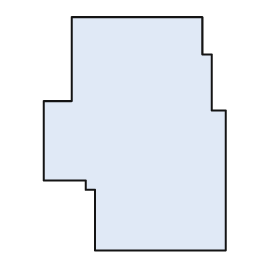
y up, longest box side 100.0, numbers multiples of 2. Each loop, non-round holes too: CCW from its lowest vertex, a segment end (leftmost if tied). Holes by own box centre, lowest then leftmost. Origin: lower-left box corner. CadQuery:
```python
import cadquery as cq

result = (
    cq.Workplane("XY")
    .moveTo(22.0, 0.0)
    .lineTo(78.0, 0.0)
    .lineTo(78.0, 60.0)
    .lineTo(72.0, 60.0)
    .lineTo(72.0, 84.0)
    .lineTo(68.0, 84.0)
    .lineTo(68.0, 100.0)
    .lineTo(12.0, 100.0)
    .lineTo(12.0, 64.0)
    .lineTo(0.0, 64.0)
    .lineTo(0.0, 30.0)
    .lineTo(18.0, 30.0)
    .lineTo(18.0, 26.0)
    .lineTo(22.0, 26.0)
    .close()
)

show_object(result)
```